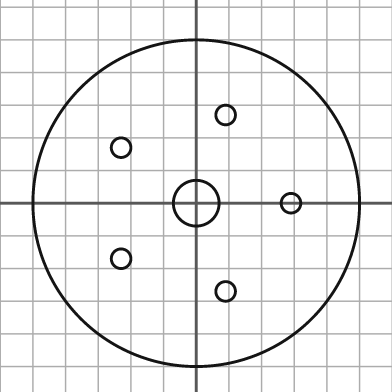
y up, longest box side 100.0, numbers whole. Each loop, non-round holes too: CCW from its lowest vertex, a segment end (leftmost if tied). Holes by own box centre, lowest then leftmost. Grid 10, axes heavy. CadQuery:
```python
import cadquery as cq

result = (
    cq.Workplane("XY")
    .moveTo(0.0, 0.0)
    .circle(50.0)
    .moveTo(9.0, -27.0)
    .circle(3.0)
    .moveTo(-23.0, -17.0)
    .circle(3.0)
    .moveTo(0.0, 0.0)
    .circle(7.0)
    .moveTo(29.0, 0.0)
    .circle(3.0)
    .moveTo(-23.0, 17.0)
    .circle(3.0)
    .moveTo(9.0, 27.0)
    .circle(3.0)
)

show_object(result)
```